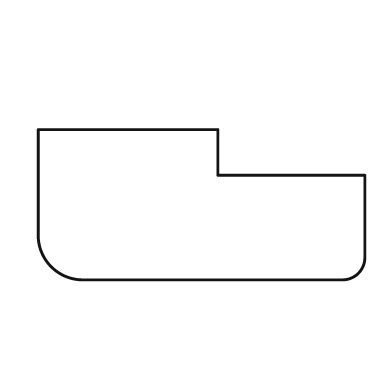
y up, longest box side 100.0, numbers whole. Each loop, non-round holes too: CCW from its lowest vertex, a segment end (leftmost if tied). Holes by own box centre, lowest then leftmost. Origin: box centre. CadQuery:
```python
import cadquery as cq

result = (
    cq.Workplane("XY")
    .moveTo(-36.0, -23.0)
    .lineTo(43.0, -23.0)
    .threePointArc((48.0, -21.0), (50.0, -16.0))
    .lineTo(50.0, 9.0)
    .lineTo(5.0, 9.0)
    .lineTo(5.0, 23.0)
    .lineTo(-50.0, 23.0)
    .lineTo(-50.0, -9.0)
    .threePointArc((-46.0, -19.0), (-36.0, -23.0))
    .close()
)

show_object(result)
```